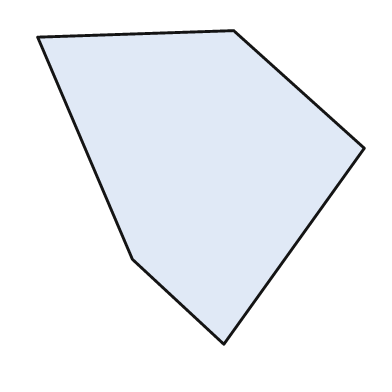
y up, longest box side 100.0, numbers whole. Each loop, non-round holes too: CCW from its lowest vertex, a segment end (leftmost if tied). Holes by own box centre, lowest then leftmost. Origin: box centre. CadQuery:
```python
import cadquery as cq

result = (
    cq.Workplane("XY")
    .moveTo(7.0, -48.0)
    .lineTo(50.0, 12.0)
    .lineTo(10.0, 48.0)
    .lineTo(-50.0, 46.0)
    .lineTo(-21.0, -22.0)
    .close()
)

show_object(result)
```